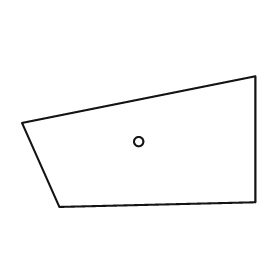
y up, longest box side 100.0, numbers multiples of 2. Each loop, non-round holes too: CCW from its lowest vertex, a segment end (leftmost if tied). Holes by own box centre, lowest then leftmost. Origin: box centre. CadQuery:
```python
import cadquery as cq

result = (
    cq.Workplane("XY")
    .moveTo(-34.0, -28.0)
    .lineTo(50.0, -26.0)
    .lineTo(50.0, 28.0)
    .lineTo(-50.0, 8.0)
    .close()
    .moveTo(0.0, 0.0)
    .circle(2.0)
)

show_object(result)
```